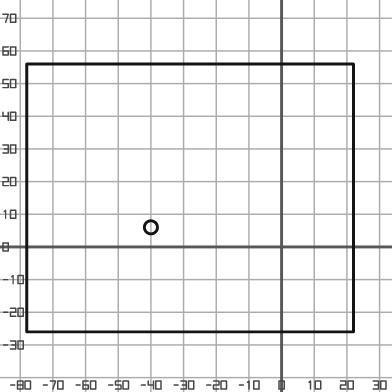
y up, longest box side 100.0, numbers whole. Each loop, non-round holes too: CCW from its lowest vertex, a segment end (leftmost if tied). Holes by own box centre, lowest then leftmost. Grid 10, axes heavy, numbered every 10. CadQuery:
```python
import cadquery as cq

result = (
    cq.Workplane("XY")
    .moveTo(-78.0, -26.0)
    .lineTo(22.0, -26.0)
    .lineTo(22.0, 56.0)
    .lineTo(-78.0, 56.0)
    .close()
    .moveTo(-40.0, 6.0)
    .circle(2.0)
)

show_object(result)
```